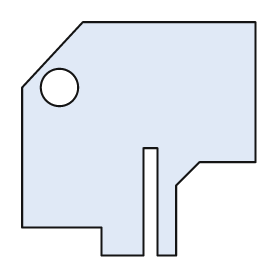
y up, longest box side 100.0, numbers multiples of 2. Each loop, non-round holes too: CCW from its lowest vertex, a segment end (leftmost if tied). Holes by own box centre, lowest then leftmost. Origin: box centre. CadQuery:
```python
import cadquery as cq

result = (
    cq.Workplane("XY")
    .moveTo(-16.0, -50.0)
    .lineTo(2.0, -50.0)
    .lineTo(2.0, -4.0)
    .lineTo(8.0, -4.0)
    .lineTo(8.0, -50.0)
    .lineTo(16.0, -50.0)
    .lineTo(16.0, -20.0)
    .lineTo(26.0, -10.0)
    .lineTo(50.0, -10.0)
    .lineTo(50.0, 50.0)
    .lineTo(-24.0, 50.0)
    .lineTo(-50.0, 22.0)
    .lineTo(-50.0, -38.0)
    .lineTo(-16.0, -38.0)
    .close()
    .moveTo(-34.0, 22.0)
    .circle(8.0)
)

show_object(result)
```